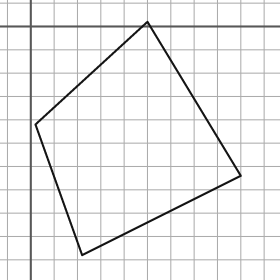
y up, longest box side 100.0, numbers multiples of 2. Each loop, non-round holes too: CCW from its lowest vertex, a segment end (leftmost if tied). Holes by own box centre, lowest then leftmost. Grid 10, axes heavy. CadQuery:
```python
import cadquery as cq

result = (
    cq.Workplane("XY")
    .moveTo(22.0, -98.0)
    .lineTo(90.0, -64.0)
    .lineTo(50.0, 2.0)
    .lineTo(2.0, -42.0)
    .close()
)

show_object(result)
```